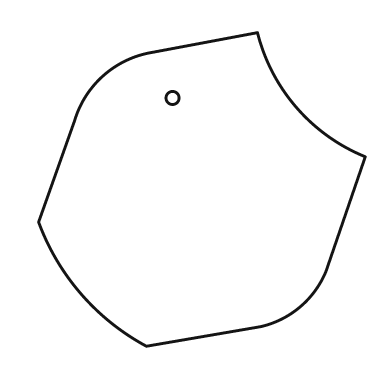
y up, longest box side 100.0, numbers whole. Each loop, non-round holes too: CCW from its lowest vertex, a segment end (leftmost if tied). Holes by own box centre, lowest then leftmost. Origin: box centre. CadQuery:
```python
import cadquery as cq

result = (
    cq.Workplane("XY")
    .moveTo(-17.0, -48.0)
    .lineTo(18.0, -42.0)
    .threePointArc((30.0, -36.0), (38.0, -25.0))
    .lineTo(50.0, 10.0)
    .threePointArc((29.0, 25.0), (17.0, 48.0))
    .lineTo(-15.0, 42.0)
    .threePointArc((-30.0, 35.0), (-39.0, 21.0))
    .lineTo(-50.0, -10.0)
    .threePointArc((-37.0, -32.0), (-17.0, -48.0))
    .close()
    .moveTo(-9.0, 28.0)
    .circle(2.0)
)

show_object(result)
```